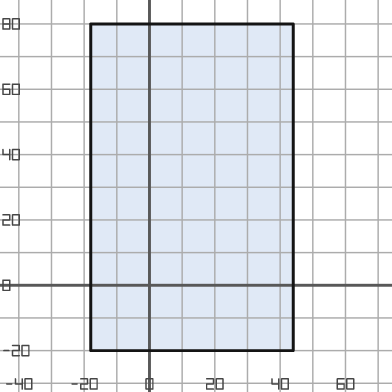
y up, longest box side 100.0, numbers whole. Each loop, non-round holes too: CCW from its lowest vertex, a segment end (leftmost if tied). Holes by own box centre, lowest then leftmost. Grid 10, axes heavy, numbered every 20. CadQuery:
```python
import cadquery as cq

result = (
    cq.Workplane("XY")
    .moveTo(-18.0, -20.0)
    .lineTo(44.0, -20.0)
    .lineTo(44.0, 80.0)
    .lineTo(-18.0, 80.0)
    .close()
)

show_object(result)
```